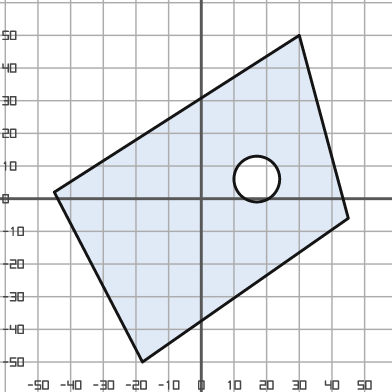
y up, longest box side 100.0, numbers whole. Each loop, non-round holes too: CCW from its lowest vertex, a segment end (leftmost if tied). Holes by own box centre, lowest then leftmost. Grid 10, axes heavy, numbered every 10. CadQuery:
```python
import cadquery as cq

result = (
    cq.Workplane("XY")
    .moveTo(-18.0, -50.0)
    .lineTo(45.0, -6.0)
    .lineTo(30.0, 50.0)
    .lineTo(-45.0, 2.0)
    .close()
    .moveTo(17.0, 6.0)
    .circle(7.0)
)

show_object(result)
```